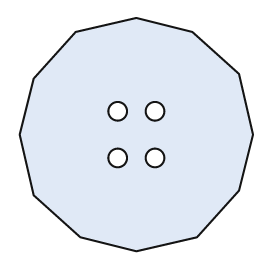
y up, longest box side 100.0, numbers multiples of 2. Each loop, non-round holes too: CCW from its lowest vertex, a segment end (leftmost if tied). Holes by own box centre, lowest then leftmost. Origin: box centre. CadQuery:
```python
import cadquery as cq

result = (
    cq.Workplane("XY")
    .moveTo(0.0, -50.0)
    .lineTo(26.0, -44.0)
    .lineTo(44.0, -24.0)
    .lineTo(50.0, 0.0)
    .lineTo(44.0, 26.0)
    .lineTo(24.0, 44.0)
    .lineTo(0.0, 50.0)
    .lineTo(-26.0, 44.0)
    .lineTo(-44.0, 24.0)
    .lineTo(-50.0, 0.0)
    .lineTo(-44.0, -26.0)
    .lineTo(-24.0, -44.0)
    .close()
    .moveTo(-8.0, -10.0)
    .circle(4.0)
    .moveTo(8.0, -10.0)
    .circle(4.0)
    .moveTo(-8.0, 10.0)
    .circle(4.0)
    .moveTo(8.0, 10.0)
    .circle(4.0)
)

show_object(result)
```